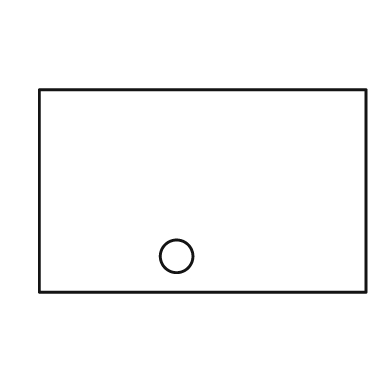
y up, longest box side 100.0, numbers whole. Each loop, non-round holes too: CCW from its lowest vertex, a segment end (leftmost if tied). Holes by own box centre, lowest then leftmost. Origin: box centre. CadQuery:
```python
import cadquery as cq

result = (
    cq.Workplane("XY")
    .moveTo(-50.0, -31.0)
    .lineTo(50.0, -31.0)
    .lineTo(50.0, 31.0)
    .lineTo(-50.0, 31.0)
    .close()
    .moveTo(-8.0, -20.0)
    .circle(5.0)
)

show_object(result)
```